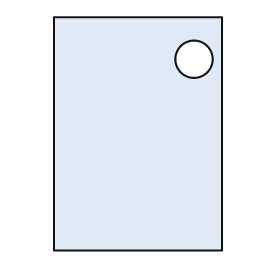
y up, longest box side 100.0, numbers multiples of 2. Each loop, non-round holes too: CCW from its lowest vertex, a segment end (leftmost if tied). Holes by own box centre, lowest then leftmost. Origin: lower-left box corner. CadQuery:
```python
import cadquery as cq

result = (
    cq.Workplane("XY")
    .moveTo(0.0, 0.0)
    .lineTo(72.0, 0.0)
    .lineTo(72.0, 100.0)
    .lineTo(0.0, 100.0)
    .close()
    .moveTo(60.0, 82.0)
    .circle(8.0)
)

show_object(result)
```